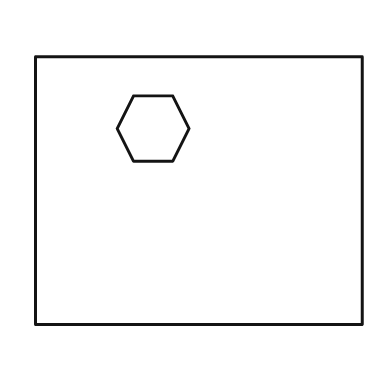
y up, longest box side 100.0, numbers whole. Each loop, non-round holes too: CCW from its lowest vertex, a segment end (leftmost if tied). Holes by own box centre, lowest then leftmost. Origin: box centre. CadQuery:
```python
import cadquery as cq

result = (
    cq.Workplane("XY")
    .moveTo(-50.0, -41.0)
    .lineTo(50.0, -41.0)
    .lineTo(50.0, 41.0)
    .lineTo(-50.0, 41.0)
    .close()
    .moveTo(-20.0, 9.0)
    .lineTo(-8.0, 9.0)
    .lineTo(-3.0, 19.0)
    .lineTo(-8.0, 29.0)
    .lineTo(-20.0, 29.0)
    .lineTo(-25.0, 19.0)
    .close()
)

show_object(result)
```